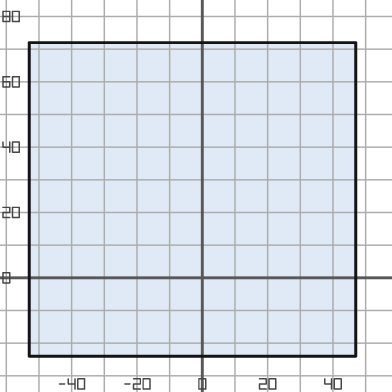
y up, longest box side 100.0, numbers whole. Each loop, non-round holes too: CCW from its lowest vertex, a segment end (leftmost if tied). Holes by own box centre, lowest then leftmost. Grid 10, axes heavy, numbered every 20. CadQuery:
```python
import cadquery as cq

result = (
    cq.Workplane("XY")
    .moveTo(-53.0, -24.0)
    .lineTo(47.0, -24.0)
    .lineTo(47.0, 72.0)
    .lineTo(-53.0, 72.0)
    .close()
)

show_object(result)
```